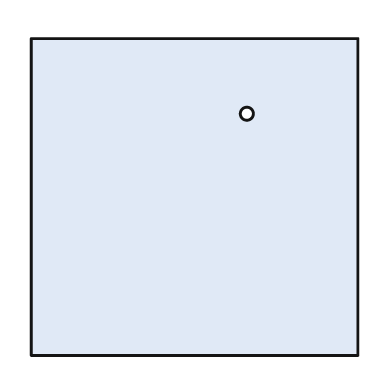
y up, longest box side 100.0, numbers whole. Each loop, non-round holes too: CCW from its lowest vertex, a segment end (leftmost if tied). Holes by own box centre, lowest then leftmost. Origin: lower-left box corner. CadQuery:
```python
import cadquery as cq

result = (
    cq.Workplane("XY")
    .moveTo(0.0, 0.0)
    .lineTo(100.0, 0.0)
    .lineTo(100.0, 97.0)
    .lineTo(0.0, 97.0)
    .close()
    .moveTo(66.0, 74.0)
    .circle(2.0)
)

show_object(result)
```